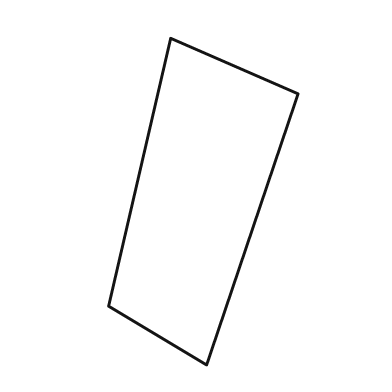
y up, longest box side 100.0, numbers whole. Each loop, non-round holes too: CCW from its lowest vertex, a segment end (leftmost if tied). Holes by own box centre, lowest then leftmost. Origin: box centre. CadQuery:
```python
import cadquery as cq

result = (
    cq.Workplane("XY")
    .moveTo(1.0, -50.0)
    .lineTo(29.0, 33.0)
    .lineTo(-10.0, 50.0)
    .lineTo(-29.0, -32.0)
    .close()
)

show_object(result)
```